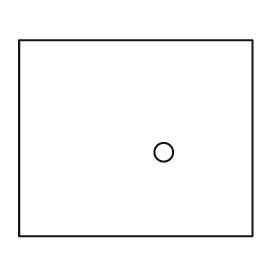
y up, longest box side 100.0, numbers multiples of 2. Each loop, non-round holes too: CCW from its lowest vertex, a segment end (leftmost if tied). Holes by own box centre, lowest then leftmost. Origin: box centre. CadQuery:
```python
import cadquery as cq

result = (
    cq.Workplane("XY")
    .moveTo(-50.0, -42.0)
    .lineTo(50.0, -42.0)
    .lineTo(50.0, 42.0)
    .lineTo(-50.0, 42.0)
    .close()
    .moveTo(12.0, -6.0)
    .circle(4.0)
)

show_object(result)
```